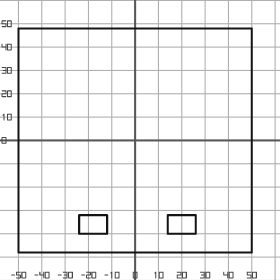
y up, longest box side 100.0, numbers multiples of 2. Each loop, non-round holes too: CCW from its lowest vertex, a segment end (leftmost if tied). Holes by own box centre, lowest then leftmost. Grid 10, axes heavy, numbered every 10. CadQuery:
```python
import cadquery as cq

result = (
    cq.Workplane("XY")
    .moveTo(-50.0, -48.0)
    .lineTo(50.0, -48.0)
    .lineTo(50.0, 48.0)
    .lineTo(-50.0, 48.0)
    .close()
    .moveTo(-24.0, -40.0)
    .lineTo(-12.0, -40.0)
    .lineTo(-12.0, -32.0)
    .lineTo(-24.0, -32.0)
    .close()
    .moveTo(14.0, -40.0)
    .lineTo(26.0, -40.0)
    .lineTo(26.0, -32.0)
    .lineTo(14.0, -32.0)
    .close()
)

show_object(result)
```